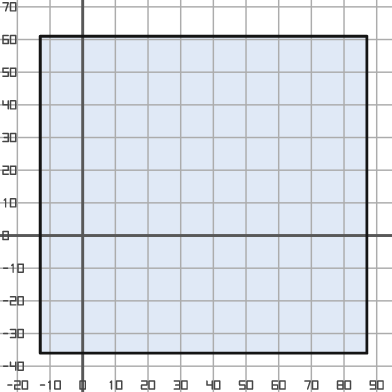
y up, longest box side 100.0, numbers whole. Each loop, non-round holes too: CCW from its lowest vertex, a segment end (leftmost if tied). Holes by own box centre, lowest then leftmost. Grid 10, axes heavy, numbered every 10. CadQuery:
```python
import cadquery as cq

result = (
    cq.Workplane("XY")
    .moveTo(-13.0, -36.0)
    .lineTo(87.0, -36.0)
    .lineTo(87.0, 61.0)
    .lineTo(-13.0, 61.0)
    .close()
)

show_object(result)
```